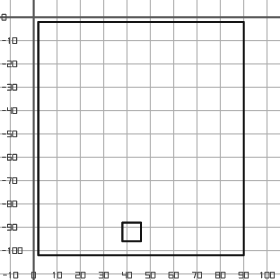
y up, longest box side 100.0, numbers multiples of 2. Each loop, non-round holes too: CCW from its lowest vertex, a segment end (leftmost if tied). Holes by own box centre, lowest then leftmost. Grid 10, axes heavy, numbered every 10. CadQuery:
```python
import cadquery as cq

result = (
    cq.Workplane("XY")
    .moveTo(2.0, -102.0)
    .lineTo(90.0, -102.0)
    .lineTo(90.0, -2.0)
    .lineTo(2.0, -2.0)
    .close()
    .moveTo(38.0, -96.0)
    .lineTo(46.0, -96.0)
    .lineTo(46.0, -88.0)
    .lineTo(38.0, -88.0)
    .close()
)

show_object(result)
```